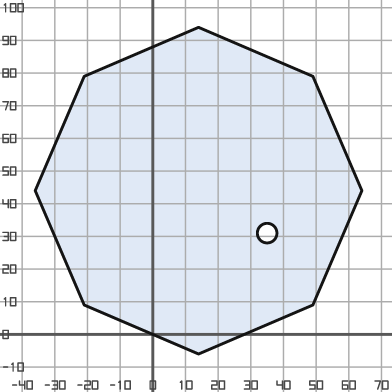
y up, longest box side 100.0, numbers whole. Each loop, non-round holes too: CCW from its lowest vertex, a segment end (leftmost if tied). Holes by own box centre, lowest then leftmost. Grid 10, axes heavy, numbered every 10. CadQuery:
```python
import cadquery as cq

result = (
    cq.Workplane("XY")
    .moveTo(14.0, -6.0)
    .lineTo(49.0, 9.0)
    .lineTo(64.0, 44.0)
    .lineTo(49.0, 79.0)
    .lineTo(14.0, 94.0)
    .lineTo(-21.0, 79.0)
    .lineTo(-36.0, 44.0)
    .lineTo(-21.0, 9.0)
    .close()
    .moveTo(35.0, 31.0)
    .circle(3.0)
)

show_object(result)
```